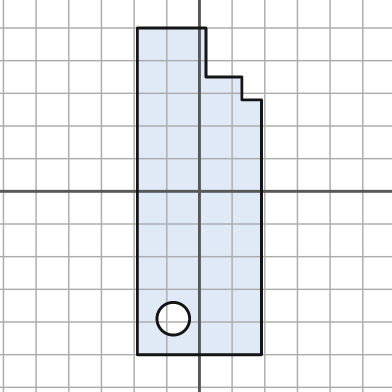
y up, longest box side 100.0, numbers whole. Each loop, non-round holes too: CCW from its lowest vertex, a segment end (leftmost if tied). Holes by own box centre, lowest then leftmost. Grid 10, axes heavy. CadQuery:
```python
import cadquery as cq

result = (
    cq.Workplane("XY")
    .moveTo(-19.0, -50.0)
    .lineTo(19.0, -50.0)
    .lineTo(19.0, 28.0)
    .lineTo(13.0, 28.0)
    .lineTo(13.0, 35.0)
    .lineTo(2.0, 35.0)
    .lineTo(2.0, 50.0)
    .lineTo(-19.0, 50.0)
    .close()
    .moveTo(-8.0, -39.0)
    .circle(5.0)
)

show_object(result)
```